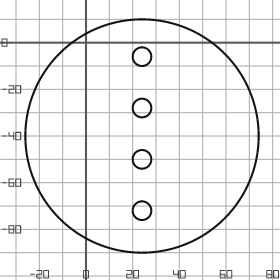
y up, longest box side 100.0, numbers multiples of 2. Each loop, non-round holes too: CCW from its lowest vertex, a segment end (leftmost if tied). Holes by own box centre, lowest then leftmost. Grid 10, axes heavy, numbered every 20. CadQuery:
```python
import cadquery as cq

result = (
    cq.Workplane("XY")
    .moveTo(24.0, -40.0)
    .circle(50.0)
    .moveTo(24.0, -72.0)
    .circle(4.0)
    .moveTo(24.0, -50.0)
    .circle(4.0)
    .moveTo(24.0, -28.0)
    .circle(4.0)
    .moveTo(24.0, -6.0)
    .circle(4.0)
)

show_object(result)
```